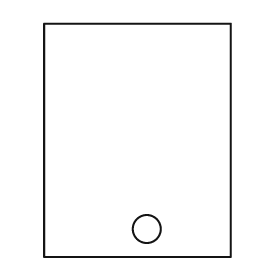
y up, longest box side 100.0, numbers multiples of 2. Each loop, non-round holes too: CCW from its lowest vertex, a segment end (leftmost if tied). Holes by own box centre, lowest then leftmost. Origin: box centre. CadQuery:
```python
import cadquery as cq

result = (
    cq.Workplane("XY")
    .moveTo(-40.0, -50.0)
    .lineTo(40.0, -50.0)
    .lineTo(40.0, 50.0)
    .lineTo(-40.0, 50.0)
    .close()
    .moveTo(4.0, -38.0)
    .circle(6.0)
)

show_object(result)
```